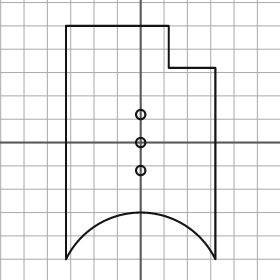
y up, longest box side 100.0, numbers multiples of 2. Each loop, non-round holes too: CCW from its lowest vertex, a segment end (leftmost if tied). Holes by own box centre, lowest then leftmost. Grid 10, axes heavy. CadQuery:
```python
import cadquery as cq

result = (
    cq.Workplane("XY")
    .moveTo(-32.0, -50.0)
    .threePointArc((0.0, -30.0), (32.0, -50.0))
    .lineTo(32.0, 32.0)
    .lineTo(12.0, 32.0)
    .lineTo(12.0, 50.0)
    .lineTo(-32.0, 50.0)
    .close()
    .moveTo(0.0, -12.0)
    .circle(2.0)
    .moveTo(0.0, 0.0)
    .circle(2.0)
    .moveTo(0.0, 12.0)
    .circle(2.0)
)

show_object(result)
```